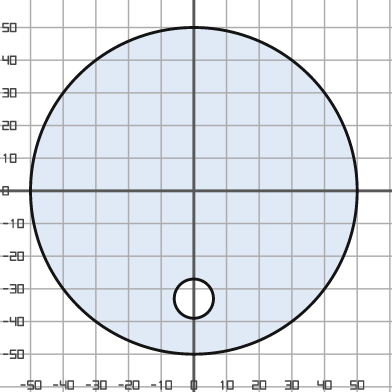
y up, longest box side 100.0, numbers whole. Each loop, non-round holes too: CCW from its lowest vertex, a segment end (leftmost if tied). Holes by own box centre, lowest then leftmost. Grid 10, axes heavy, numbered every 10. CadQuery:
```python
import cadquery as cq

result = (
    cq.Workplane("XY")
    .moveTo(0.0, 0.0)
    .circle(50.0)
    .moveTo(0.0, -33.0)
    .circle(6.0)
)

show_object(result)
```